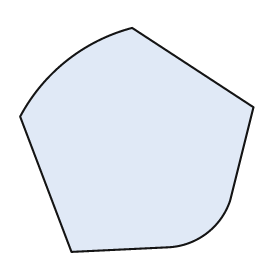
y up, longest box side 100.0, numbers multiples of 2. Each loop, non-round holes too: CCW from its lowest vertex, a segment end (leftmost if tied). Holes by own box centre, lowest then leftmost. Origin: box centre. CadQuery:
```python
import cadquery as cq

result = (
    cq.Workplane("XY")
    .moveTo(-28.0, -48.0)
    .lineTo(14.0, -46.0)
    .threePointArc((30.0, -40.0), (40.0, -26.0))
    .lineTo(50.0, 14.0)
    .lineTo(-2.0, 48.0)
    .threePointArc((-30.0, 34.0), (-50.0, 10.0))
    .close()
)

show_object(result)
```